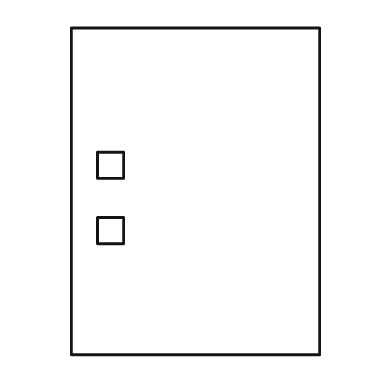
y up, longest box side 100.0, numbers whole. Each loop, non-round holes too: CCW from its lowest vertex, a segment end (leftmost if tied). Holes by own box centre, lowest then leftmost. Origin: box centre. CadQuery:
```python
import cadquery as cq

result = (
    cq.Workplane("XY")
    .moveTo(-38.0, -50.0)
    .lineTo(38.0, -50.0)
    .lineTo(38.0, 50.0)
    .lineTo(-38.0, 50.0)
    .close()
    .moveTo(-30.0, -16.0)
    .lineTo(-22.0, -16.0)
    .lineTo(-22.0, -8.0)
    .lineTo(-30.0, -8.0)
    .close()
    .moveTo(-30.0, 4.0)
    .lineTo(-22.0, 4.0)
    .lineTo(-22.0, 12.0)
    .lineTo(-30.0, 12.0)
    .close()
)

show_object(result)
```